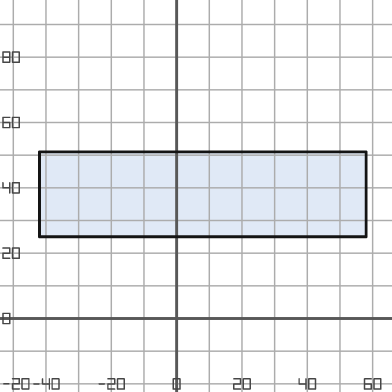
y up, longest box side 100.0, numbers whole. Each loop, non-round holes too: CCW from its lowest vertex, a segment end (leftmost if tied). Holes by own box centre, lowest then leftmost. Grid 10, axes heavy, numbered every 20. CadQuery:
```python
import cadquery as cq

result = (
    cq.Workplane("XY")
    .moveTo(-42.0, 25.0)
    .lineTo(58.0, 25.0)
    .lineTo(58.0, 51.0)
    .lineTo(-42.0, 51.0)
    .close()
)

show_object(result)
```